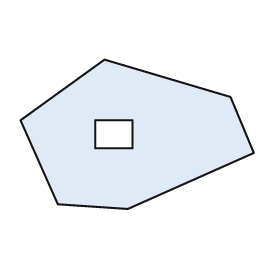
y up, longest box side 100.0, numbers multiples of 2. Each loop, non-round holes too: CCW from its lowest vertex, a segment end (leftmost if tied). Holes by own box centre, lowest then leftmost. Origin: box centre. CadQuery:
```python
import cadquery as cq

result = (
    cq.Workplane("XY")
    .moveTo(-4.0, -32.0)
    .lineTo(50.0, -8.0)
    .lineTo(40.0, 16.0)
    .lineTo(-14.0, 32.0)
    .lineTo(-50.0, 6.0)
    .lineTo(-34.0, -30.0)
    .close()
    .moveTo(-18.0, -6.0)
    .lineTo(-2.0, -6.0)
    .lineTo(-2.0, 6.0)
    .lineTo(-18.0, 6.0)
    .close()
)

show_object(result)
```